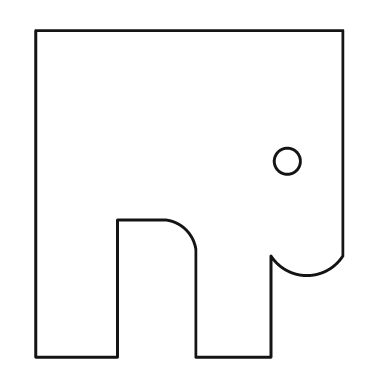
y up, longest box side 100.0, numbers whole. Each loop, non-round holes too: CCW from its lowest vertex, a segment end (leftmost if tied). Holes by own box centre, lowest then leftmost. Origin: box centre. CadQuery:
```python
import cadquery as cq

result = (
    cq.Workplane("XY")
    .moveTo(-47.0, -50.0)
    .lineTo(-22.0, -50.0)
    .lineTo(-22.0, -8.0)
    .lineTo(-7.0, -8.0)
    .threePointArc((-1.0, -11.0), (2.0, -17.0))
    .lineTo(2.0, -50.0)
    .lineTo(25.0, -50.0)
    .lineTo(25.0, -19.0)
    .threePointArc((36.0, -25.0), (47.0, -19.0))
    .lineTo(47.0, 50.0)
    .lineTo(-47.0, 50.0)
    .close()
    .moveTo(30.0, 10.0)
    .circle(4.0)
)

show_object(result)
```